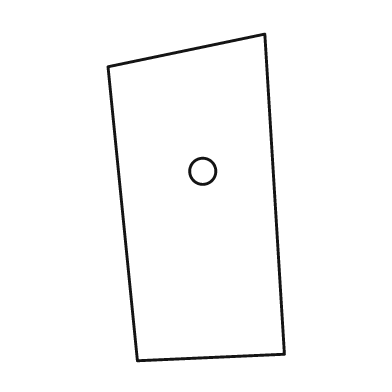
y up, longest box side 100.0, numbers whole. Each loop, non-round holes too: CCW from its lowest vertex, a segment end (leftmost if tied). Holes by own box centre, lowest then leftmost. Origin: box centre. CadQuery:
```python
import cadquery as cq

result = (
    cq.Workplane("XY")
    .moveTo(-18.0, -50.0)
    .lineTo(27.0, -48.0)
    .lineTo(21.0, 50.0)
    .lineTo(-27.0, 40.0)
    .close()
    .moveTo(2.0, 8.0)
    .circle(4.0)
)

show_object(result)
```